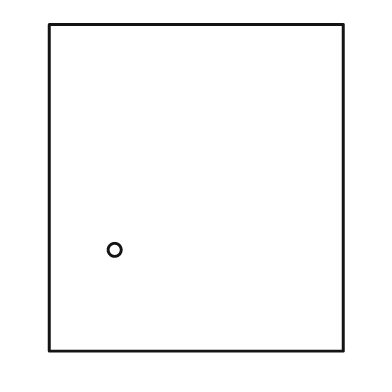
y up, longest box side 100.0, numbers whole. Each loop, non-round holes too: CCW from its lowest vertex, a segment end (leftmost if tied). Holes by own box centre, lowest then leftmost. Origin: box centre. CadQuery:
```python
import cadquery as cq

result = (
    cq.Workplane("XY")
    .moveTo(-45.0, -50.0)
    .lineTo(45.0, -50.0)
    .lineTo(45.0, 50.0)
    .lineTo(-45.0, 50.0)
    .close()
    .moveTo(-25.0, -19.0)
    .circle(2.0)
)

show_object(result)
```